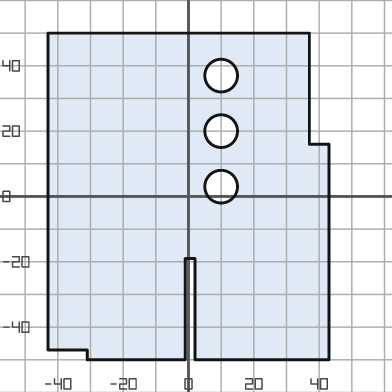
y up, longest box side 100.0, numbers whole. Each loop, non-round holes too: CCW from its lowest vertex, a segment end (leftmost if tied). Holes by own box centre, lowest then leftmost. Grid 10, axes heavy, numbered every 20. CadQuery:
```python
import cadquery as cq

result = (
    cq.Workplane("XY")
    .moveTo(-31.0, -50.0)
    .lineTo(-1.0, -50.0)
    .lineTo(-1.0, -19.0)
    .lineTo(2.0, -19.0)
    .lineTo(2.0, -50.0)
    .lineTo(43.0, -50.0)
    .lineTo(43.0, 16.0)
    .lineTo(37.0, 16.0)
    .lineTo(37.0, 50.0)
    .lineTo(-43.0, 50.0)
    .lineTo(-43.0, -47.0)
    .lineTo(-31.0, -47.0)
    .close()
    .moveTo(10.0, 3.0)
    .circle(5.0)
    .moveTo(10.0, 20.0)
    .circle(5.0)
    .moveTo(10.0, 37.0)
    .circle(5.0)
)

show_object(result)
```